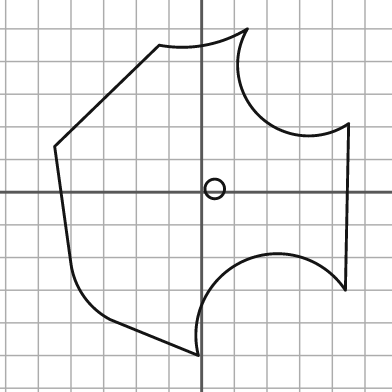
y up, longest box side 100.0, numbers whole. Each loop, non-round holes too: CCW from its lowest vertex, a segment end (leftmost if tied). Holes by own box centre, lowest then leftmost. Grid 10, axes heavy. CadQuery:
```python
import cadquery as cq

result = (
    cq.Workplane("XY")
    .moveTo(-1.0, -50.0)
    .threePointArc((13.0, -21.0), (44.0, -30.0))
    .lineTo(45.0, 21.0)
    .threePointArc((18.0, 23.0), (14.0, 50.0))
    .threePointArc((1.0, 45.0), (-13.0, 45.0))
    .lineTo(-45.0, 14.0)
    .lineTo(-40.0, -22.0)
    .threePointArc((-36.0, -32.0), (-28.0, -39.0))
    .close()
    .moveTo(4.0, 1.0)
    .circle(3.0)
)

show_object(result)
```